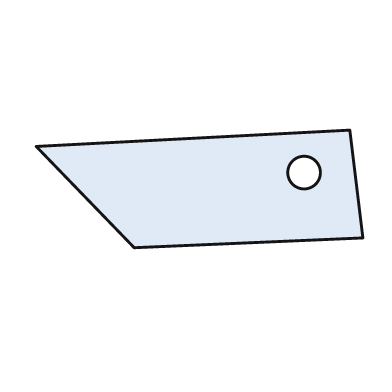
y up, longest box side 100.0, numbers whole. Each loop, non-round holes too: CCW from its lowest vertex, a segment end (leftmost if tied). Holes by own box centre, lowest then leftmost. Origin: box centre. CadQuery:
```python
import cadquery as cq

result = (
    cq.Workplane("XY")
    .moveTo(-20.0, -18.0)
    .lineTo(50.0, -15.0)
    .lineTo(46.0, 18.0)
    .lineTo(-50.0, 13.0)
    .close()
    .moveTo(32.0, 5.0)
    .circle(5.0)
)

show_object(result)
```